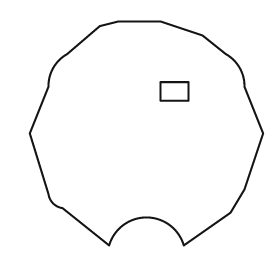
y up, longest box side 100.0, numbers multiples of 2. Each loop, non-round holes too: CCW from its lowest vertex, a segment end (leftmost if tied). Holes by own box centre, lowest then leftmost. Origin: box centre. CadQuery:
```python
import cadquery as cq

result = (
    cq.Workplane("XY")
    .moveTo(-16.0, -48.0)
    .threePointArc((0.0, -36.0), (16.0, -48.0))
    .lineTo(36.0, -34.0)
    .lineTo(42.0, -24.0)
    .lineTo(50.0, 0.0)
    .lineTo(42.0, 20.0)
    .threePointArc((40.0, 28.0), (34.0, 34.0))
    .lineTo(24.0, 42.0)
    .lineTo(6.0, 48.0)
    .lineTo(-12.0, 48.0)
    .lineTo(-20.0, 46.0)
    .lineTo(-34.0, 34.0)
    .threePointArc((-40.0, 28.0), (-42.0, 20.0))
    .lineTo(-50.0, 0.0)
    .lineTo(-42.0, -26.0)
    .threePointArc((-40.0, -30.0), (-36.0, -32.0))
    .close()
    .moveTo(6.0, 14.0)
    .lineTo(18.0, 14.0)
    .lineTo(18.0, 22.0)
    .lineTo(6.0, 22.0)
    .close()
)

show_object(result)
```